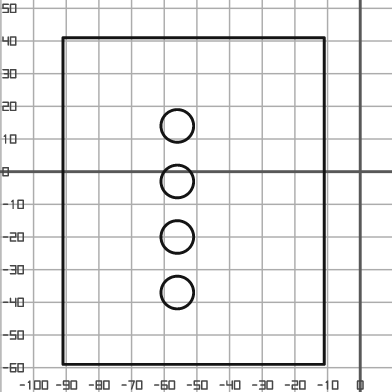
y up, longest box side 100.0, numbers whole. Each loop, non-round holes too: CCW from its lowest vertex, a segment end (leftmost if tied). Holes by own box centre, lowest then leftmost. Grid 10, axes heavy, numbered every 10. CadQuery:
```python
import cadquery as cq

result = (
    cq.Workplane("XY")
    .moveTo(-91.0, -59.0)
    .lineTo(-11.0, -59.0)
    .lineTo(-11.0, 41.0)
    .lineTo(-91.0, 41.0)
    .close()
    .moveTo(-56.0, -37.0)
    .circle(5.0)
    .moveTo(-56.0, -20.0)
    .circle(5.0)
    .moveTo(-56.0, -3.0)
    .circle(5.0)
    .moveTo(-56.0, 14.0)
    .circle(5.0)
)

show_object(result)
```